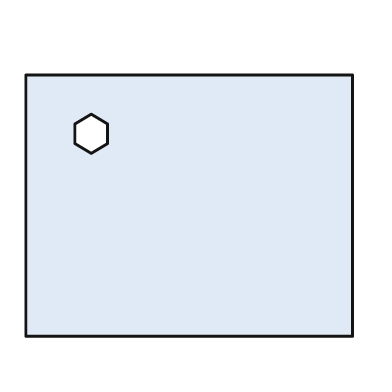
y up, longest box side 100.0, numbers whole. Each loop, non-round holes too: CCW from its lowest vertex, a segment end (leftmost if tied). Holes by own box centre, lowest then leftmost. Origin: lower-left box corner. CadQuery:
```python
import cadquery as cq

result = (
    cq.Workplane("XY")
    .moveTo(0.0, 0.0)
    .lineTo(100.0, 0.0)
    .lineTo(100.0, 80.0)
    .lineTo(0.0, 80.0)
    .close()
    .moveTo(20.0, 56.0)
    .lineTo(25.0, 59.0)
    .lineTo(25.0, 65.0)
    .lineTo(20.0, 68.0)
    .lineTo(15.0, 65.0)
    .lineTo(15.0, 59.0)
    .close()
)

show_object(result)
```